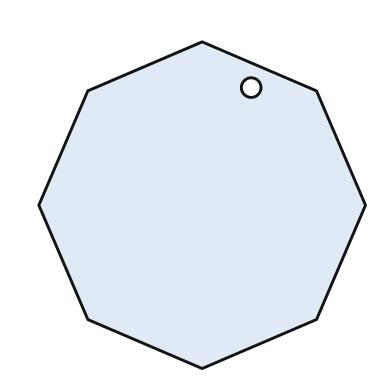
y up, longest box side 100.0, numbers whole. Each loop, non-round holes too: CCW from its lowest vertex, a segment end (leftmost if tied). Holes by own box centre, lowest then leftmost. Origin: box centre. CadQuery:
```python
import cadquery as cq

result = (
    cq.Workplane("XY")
    .moveTo(0.0, -50.0)
    .lineTo(35.0, -35.0)
    .lineTo(50.0, 0.0)
    .lineTo(35.0, 35.0)
    .lineTo(0.0, 50.0)
    .lineTo(-35.0, 35.0)
    .lineTo(-50.0, 0.0)
    .lineTo(-35.0, -35.0)
    .close()
    .moveTo(15.0, 36.0)
    .circle(3.0)
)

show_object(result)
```